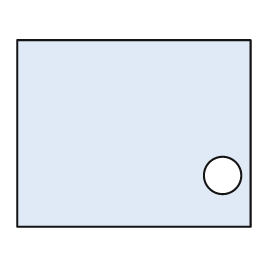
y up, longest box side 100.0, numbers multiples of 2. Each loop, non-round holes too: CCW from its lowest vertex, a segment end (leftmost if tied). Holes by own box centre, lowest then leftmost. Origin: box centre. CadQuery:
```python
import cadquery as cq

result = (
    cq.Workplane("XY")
    .moveTo(-50.0, -40.0)
    .lineTo(50.0, -40.0)
    .lineTo(50.0, 40.0)
    .lineTo(-50.0, 40.0)
    .close()
    .moveTo(38.0, -18.0)
    .circle(8.0)
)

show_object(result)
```